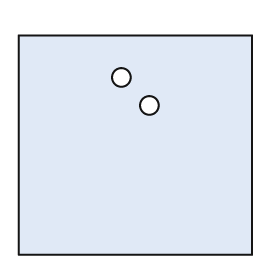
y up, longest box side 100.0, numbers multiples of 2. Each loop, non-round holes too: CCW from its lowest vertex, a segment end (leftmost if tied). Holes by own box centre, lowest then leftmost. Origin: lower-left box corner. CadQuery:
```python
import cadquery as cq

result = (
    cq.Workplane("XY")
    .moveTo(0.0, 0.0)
    .lineTo(100.0, 0.0)
    .lineTo(100.0, 94.0)
    .lineTo(0.0, 94.0)
    .close()
    .moveTo(56.0, 64.0)
    .circle(4.0)
    .moveTo(44.0, 76.0)
    .circle(4.0)
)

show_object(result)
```